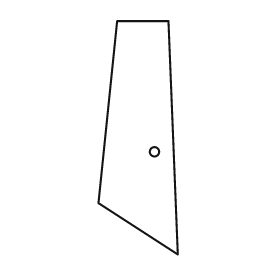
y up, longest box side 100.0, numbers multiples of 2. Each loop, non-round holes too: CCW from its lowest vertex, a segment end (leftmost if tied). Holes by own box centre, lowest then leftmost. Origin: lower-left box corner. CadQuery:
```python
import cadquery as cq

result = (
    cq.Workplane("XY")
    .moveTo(34.0, 0.0)
    .lineTo(30.0, 100.0)
    .lineTo(8.0, 100.0)
    .lineTo(0.0, 22.0)
    .close()
    .moveTo(24.0, 44.0)
    .circle(2.0)
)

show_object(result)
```